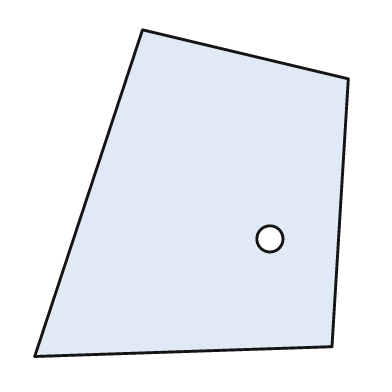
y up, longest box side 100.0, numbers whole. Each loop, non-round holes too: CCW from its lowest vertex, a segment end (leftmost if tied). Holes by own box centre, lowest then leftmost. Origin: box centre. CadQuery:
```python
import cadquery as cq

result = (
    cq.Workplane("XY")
    .moveTo(-48.0, -50.0)
    .lineTo(43.0, -47.0)
    .lineTo(48.0, 35.0)
    .lineTo(-15.0, 50.0)
    .close()
    .moveTo(24.0, -14.0)
    .circle(4.0)
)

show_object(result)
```